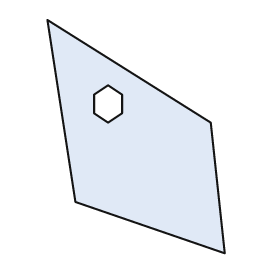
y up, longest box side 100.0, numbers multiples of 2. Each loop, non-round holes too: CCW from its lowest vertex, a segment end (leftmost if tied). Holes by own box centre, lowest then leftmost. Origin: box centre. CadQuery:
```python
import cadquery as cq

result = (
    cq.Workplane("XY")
    .moveTo(38.0, -50.0)
    .lineTo(32.0, 6.0)
    .lineTo(-38.0, 50.0)
    .lineTo(-26.0, -28.0)
    .close()
    .moveTo(-12.0, 6.0)
    .lineTo(-6.0, 10.0)
    .lineTo(-6.0, 18.0)
    .lineTo(-12.0, 22.0)
    .lineTo(-18.0, 18.0)
    .lineTo(-18.0, 10.0)
    .close()
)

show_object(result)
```